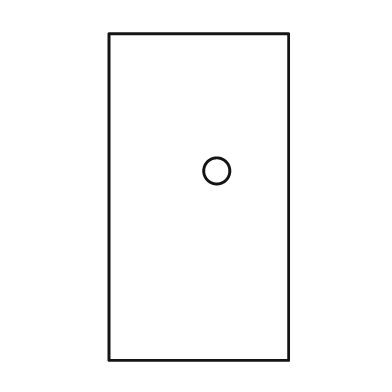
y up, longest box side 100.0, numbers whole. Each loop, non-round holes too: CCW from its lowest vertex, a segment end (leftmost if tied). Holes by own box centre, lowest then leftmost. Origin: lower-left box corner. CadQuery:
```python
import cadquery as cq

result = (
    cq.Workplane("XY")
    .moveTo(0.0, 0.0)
    .lineTo(55.0, 0.0)
    .lineTo(55.0, 100.0)
    .lineTo(0.0, 100.0)
    .close()
    .moveTo(33.0, 58.0)
    .circle(4.0)
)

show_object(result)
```